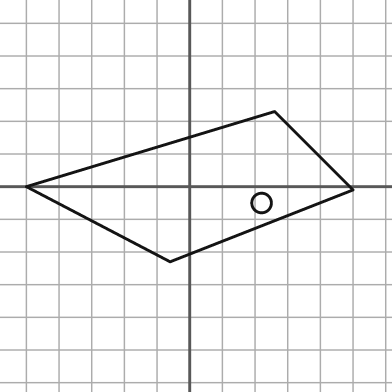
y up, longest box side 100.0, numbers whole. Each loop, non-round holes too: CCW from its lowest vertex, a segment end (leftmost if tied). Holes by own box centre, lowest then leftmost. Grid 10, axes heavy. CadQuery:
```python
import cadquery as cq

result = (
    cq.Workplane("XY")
    .moveTo(-6.0, -23.0)
    .lineTo(50.0, -1.0)
    .lineTo(26.0, 23.0)
    .lineTo(-50.0, 0.0)
    .close()
    .moveTo(22.0, -5.0)
    .circle(3.0)
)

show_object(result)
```